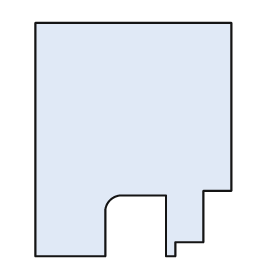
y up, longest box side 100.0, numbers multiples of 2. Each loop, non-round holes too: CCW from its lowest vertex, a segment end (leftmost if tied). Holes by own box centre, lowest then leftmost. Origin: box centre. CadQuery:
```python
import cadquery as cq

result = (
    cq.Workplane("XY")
    .moveTo(-42.0, -50.0)
    .lineTo(-12.0, -50.0)
    .lineTo(-12.0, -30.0)
    .threePointArc((-10.0, -26.0), (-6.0, -24.0))
    .lineTo(14.0, -24.0)
    .lineTo(14.0, -50.0)
    .lineTo(18.0, -50.0)
    .lineTo(18.0, -44.0)
    .lineTo(30.0, -44.0)
    .lineTo(30.0, -22.0)
    .lineTo(42.0, -22.0)
    .lineTo(42.0, 50.0)
    .lineTo(-42.0, 50.0)
    .close()
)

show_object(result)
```